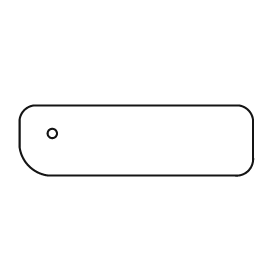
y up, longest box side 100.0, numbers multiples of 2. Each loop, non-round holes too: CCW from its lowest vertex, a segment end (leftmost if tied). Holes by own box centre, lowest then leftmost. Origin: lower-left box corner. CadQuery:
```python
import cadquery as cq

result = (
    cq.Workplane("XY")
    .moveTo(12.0, 0.0)
    .lineTo(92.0, 0.0)
    .threePointArc((98.0, 2.0), (100.0, 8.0))
    .lineTo(100.0, 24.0)
    .threePointArc((98.0, 28.0), (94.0, 30.0))
    .lineTo(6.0, 30.0)
    .threePointArc((2.0, 28.0), (0.0, 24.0))
    .lineTo(0.0, 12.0)
    .threePointArc((4.0, 4.0), (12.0, 0.0))
    .close()
    .moveTo(14.0, 18.0)
    .circle(2.0)
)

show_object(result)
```